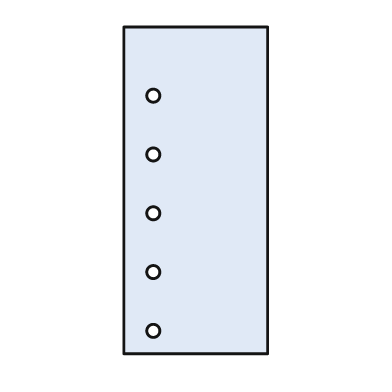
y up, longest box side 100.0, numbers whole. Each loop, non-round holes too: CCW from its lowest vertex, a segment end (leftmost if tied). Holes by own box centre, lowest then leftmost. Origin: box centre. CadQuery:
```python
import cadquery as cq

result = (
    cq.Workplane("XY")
    .moveTo(-22.0, -50.0)
    .lineTo(22.0, -50.0)
    .lineTo(22.0, 50.0)
    .lineTo(-22.0, 50.0)
    .close()
    .moveTo(-13.0, -43.0)
    .circle(2.0)
    .moveTo(-13.0, -25.0)
    .circle(2.0)
    .moveTo(-13.0, -7.0)
    .circle(2.0)
    .moveTo(-13.0, 11.0)
    .circle(2.0)
    .moveTo(-13.0, 29.0)
    .circle(2.0)
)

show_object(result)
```